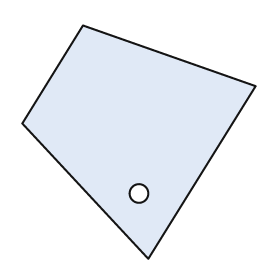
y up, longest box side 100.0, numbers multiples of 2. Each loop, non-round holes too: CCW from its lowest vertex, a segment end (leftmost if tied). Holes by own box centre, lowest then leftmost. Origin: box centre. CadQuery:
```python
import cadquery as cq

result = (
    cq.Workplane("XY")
    .moveTo(4.0, -50.0)
    .lineTo(50.0, 24.0)
    .lineTo(-24.0, 50.0)
    .lineTo(-50.0, 8.0)
    .close()
    .moveTo(0.0, -22.0)
    .circle(4.0)
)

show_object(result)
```